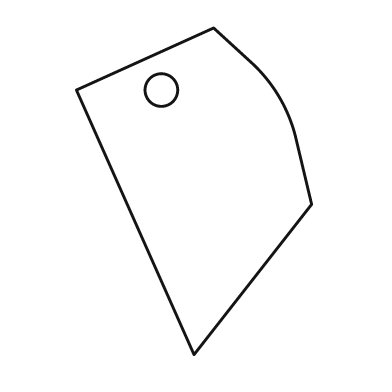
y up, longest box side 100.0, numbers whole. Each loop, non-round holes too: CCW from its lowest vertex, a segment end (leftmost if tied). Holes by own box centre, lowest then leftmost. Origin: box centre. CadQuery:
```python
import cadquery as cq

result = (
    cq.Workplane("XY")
    .moveTo(0.0, -50.0)
    .lineTo(36.0, -4.0)
    .lineTo(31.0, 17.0)
    .threePointArc((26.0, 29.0), (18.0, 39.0))
    .lineTo(6.0, 50.0)
    .lineTo(-36.0, 31.0)
    .close()
    .moveTo(-10.0, 31.0)
    .circle(5.0)
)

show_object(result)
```